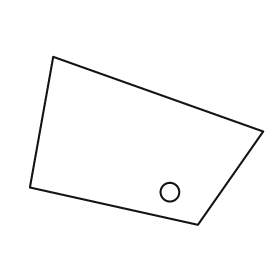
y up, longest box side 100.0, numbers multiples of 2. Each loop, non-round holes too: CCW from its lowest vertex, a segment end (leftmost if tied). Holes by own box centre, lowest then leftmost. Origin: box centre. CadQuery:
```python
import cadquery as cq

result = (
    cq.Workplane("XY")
    .moveTo(22.0, -36.0)
    .lineTo(50.0, 4.0)
    .lineTo(-40.0, 36.0)
    .lineTo(-50.0, -20.0)
    .close()
    .moveTo(10.0, -22.0)
    .circle(4.0)
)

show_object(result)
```